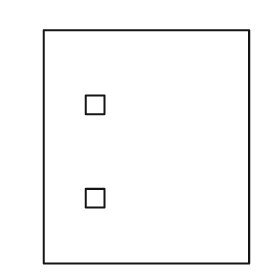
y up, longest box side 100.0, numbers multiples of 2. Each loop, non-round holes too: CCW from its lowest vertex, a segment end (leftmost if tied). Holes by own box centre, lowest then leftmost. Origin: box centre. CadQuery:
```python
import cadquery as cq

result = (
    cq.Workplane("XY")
    .moveTo(-44.0, -50.0)
    .lineTo(44.0, -50.0)
    .lineTo(44.0, 50.0)
    .lineTo(-44.0, 50.0)
    .close()
    .moveTo(-26.0, -26.0)
    .lineTo(-18.0, -26.0)
    .lineTo(-18.0, -18.0)
    .lineTo(-26.0, -18.0)
    .close()
    .moveTo(-26.0, 14.0)
    .lineTo(-18.0, 14.0)
    .lineTo(-18.0, 22.0)
    .lineTo(-26.0, 22.0)
    .close()
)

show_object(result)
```